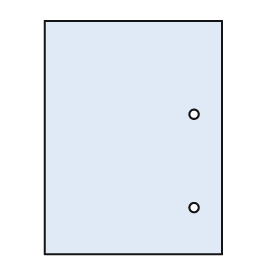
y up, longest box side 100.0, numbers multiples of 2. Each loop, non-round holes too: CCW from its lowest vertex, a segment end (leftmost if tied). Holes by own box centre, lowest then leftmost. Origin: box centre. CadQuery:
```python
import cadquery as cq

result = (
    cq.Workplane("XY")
    .moveTo(-38.0, -50.0)
    .lineTo(38.0, -50.0)
    .lineTo(38.0, 50.0)
    .lineTo(-38.0, 50.0)
    .close()
    .moveTo(26.0, -30.0)
    .circle(2.0)
    .moveTo(26.0, 10.0)
    .circle(2.0)
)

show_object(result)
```